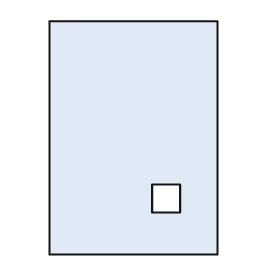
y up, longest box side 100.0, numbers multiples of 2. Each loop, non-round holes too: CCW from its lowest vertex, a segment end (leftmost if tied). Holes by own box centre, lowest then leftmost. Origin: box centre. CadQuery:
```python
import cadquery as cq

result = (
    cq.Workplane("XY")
    .moveTo(-36.0, -50.0)
    .lineTo(36.0, -50.0)
    .lineTo(36.0, 50.0)
    .lineTo(-36.0, 50.0)
    .close()
    .moveTo(8.0, -32.0)
    .lineTo(20.0, -32.0)
    .lineTo(20.0, -20.0)
    .lineTo(8.0, -20.0)
    .close()
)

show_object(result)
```